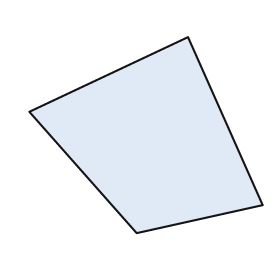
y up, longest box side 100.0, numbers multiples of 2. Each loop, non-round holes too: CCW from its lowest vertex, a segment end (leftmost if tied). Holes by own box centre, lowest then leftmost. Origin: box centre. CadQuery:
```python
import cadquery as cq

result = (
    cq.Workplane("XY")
    .moveTo(-4.0, -42.0)
    .lineTo(50.0, -30.0)
    .lineTo(18.0, 42.0)
    .lineTo(-50.0, 10.0)
    .close()
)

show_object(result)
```